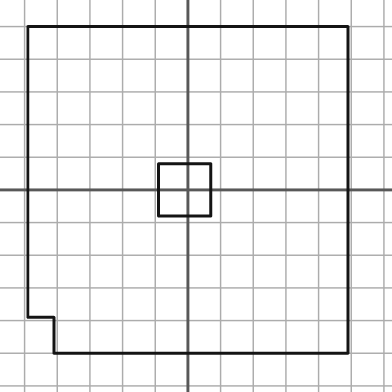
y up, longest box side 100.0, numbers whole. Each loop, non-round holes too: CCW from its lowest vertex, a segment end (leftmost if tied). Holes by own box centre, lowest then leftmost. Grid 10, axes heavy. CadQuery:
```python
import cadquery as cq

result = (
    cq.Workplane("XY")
    .moveTo(-41.0, -50.0)
    .lineTo(49.0, -50.0)
    .lineTo(49.0, 50.0)
    .lineTo(-49.0, 50.0)
    .lineTo(-49.0, -39.0)
    .lineTo(-41.0, -39.0)
    .close()
    .moveTo(-9.0, -8.0)
    .lineTo(7.0, -8.0)
    .lineTo(7.0, 8.0)
    .lineTo(-9.0, 8.0)
    .close()
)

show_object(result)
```